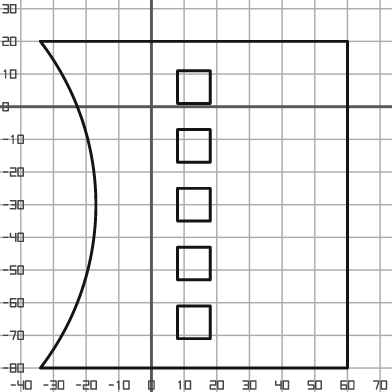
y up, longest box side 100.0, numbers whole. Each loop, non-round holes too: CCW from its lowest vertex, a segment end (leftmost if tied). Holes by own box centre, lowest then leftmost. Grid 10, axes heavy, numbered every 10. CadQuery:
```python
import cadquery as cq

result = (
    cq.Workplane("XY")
    .moveTo(-34.0, -80.0)
    .lineTo(60.0, -80.0)
    .lineTo(60.0, 20.0)
    .lineTo(-34.0, 20.0)
    .threePointArc((-17.0, -30.0), (-34.0, -80.0))
    .close()
    .moveTo(8.0, -71.0)
    .lineTo(18.0, -71.0)
    .lineTo(18.0, -61.0)
    .lineTo(8.0, -61.0)
    .close()
    .moveTo(8.0, -53.0)
    .lineTo(18.0, -53.0)
    .lineTo(18.0, -43.0)
    .lineTo(8.0, -43.0)
    .close()
    .moveTo(8.0, -35.0)
    .lineTo(18.0, -35.0)
    .lineTo(18.0, -25.0)
    .lineTo(8.0, -25.0)
    .close()
    .moveTo(8.0, -17.0)
    .lineTo(18.0, -17.0)
    .lineTo(18.0, -7.0)
    .lineTo(8.0, -7.0)
    .close()
    .moveTo(8.0, 1.0)
    .lineTo(18.0, 1.0)
    .lineTo(18.0, 11.0)
    .lineTo(8.0, 11.0)
    .close()
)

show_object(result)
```